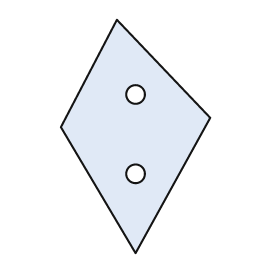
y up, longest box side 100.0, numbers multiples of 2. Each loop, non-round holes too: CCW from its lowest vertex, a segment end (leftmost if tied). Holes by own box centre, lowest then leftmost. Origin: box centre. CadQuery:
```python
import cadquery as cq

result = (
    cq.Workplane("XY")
    .moveTo(0.0, -50.0)
    .lineTo(32.0, 8.0)
    .lineTo(-8.0, 50.0)
    .lineTo(-32.0, 4.0)
    .close()
    .moveTo(0.0, -16.0)
    .circle(4.0)
    .moveTo(0.0, 18.0)
    .circle(4.0)
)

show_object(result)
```